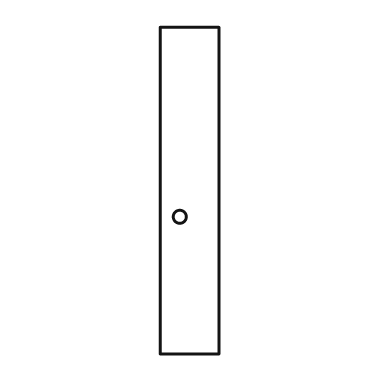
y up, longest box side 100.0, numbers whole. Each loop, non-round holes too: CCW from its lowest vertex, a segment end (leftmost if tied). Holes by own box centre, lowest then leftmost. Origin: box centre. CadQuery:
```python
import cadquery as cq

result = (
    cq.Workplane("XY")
    .moveTo(-9.0, -50.0)
    .lineTo(9.0, -50.0)
    .lineTo(9.0, 50.0)
    .lineTo(-9.0, 50.0)
    .close()
    .moveTo(-3.0, -8.0)
    .circle(2.0)
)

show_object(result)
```